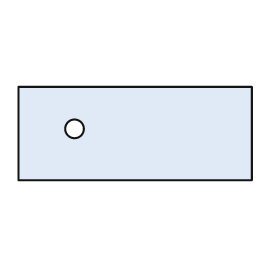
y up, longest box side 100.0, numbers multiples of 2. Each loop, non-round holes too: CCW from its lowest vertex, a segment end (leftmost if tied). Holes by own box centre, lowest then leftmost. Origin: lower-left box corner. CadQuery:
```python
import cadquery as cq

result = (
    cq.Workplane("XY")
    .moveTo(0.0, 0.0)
    .lineTo(100.0, 0.0)
    .lineTo(100.0, 40.0)
    .lineTo(0.0, 40.0)
    .close()
    .moveTo(24.0, 22.0)
    .circle(4.0)
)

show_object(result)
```